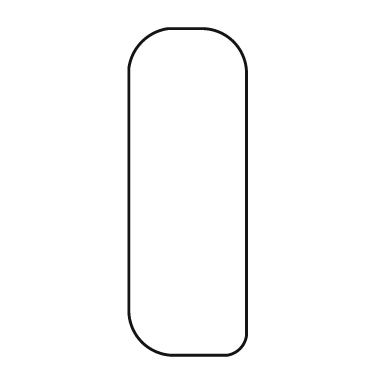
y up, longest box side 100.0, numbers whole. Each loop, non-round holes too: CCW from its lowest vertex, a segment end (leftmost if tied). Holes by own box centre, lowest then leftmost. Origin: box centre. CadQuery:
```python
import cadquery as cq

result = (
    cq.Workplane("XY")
    .moveTo(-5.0, -50.0)
    .lineTo(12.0, -50.0)
    .threePointArc((16.0, -48.0), (18.0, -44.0))
    .lineTo(18.0, 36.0)
    .threePointArc((14.0, 46.0), (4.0, 50.0))
    .lineTo(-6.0, 50.0)
    .threePointArc((-14.0, 46.0), (-18.0, 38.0))
    .lineTo(-18.0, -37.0)
    .threePointArc((-14.0, -46.0), (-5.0, -50.0))
    .close()
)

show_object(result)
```